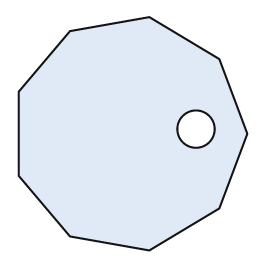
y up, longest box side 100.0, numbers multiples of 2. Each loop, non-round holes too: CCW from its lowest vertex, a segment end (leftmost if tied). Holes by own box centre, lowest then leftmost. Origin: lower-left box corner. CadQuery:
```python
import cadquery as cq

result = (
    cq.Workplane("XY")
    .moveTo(56.0, 0.0)
    .lineTo(86.0, 18.0)
    .lineTo(98.0, 50.0)
    .lineTo(86.0, 82.0)
    .lineTo(56.0, 100.0)
    .lineTo(22.0, 94.0)
    .lineTo(0.0, 68.0)
    .lineTo(0.0, 32.0)
    .lineTo(22.0, 6.0)
    .close()
    .moveTo(76.0, 52.0)
    .circle(8.0)
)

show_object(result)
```